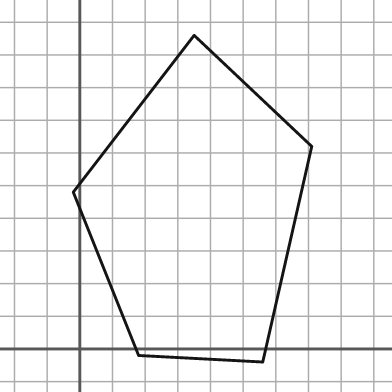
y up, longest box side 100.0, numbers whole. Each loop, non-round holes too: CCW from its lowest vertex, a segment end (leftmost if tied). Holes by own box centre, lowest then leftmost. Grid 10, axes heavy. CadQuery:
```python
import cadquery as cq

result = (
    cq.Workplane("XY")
    .moveTo(56.0, -4.0)
    .lineTo(71.0, 62.0)
    .lineTo(35.0, 96.0)
    .lineTo(-2.0, 48.0)
    .lineTo(18.0, -2.0)
    .close()
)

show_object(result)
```